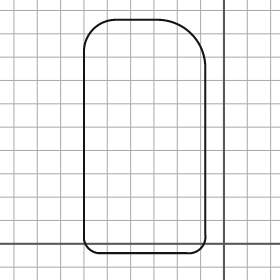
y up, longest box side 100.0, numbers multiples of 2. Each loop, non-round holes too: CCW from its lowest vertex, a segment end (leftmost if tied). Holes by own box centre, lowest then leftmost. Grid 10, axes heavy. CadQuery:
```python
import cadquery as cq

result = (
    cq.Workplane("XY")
    .moveTo(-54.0, -4.0)
    .lineTo(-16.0, -4.0)
    .threePointArc((-10.0, -2.0), (-8.0, 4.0))
    .lineTo(-8.0, 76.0)
    .threePointArc((-14.0, 90.0), (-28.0, 96.0))
    .lineTo(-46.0, 96.0)
    .threePointArc((-56.0, 92.0), (-60.0, 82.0))
    .lineTo(-60.0, 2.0)
    .threePointArc((-58.0, -2.0), (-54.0, -4.0))
    .close()
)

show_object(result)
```